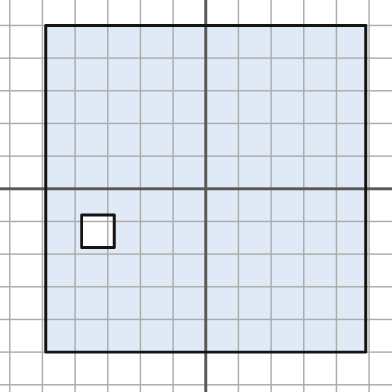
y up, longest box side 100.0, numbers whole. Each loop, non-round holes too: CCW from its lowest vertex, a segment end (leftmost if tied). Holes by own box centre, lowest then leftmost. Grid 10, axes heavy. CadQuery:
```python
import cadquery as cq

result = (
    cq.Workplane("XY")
    .moveTo(-49.0, -50.0)
    .lineTo(49.0, -50.0)
    .lineTo(49.0, 50.0)
    .lineTo(-49.0, 50.0)
    .close()
    .moveTo(-38.0, -18.0)
    .lineTo(-28.0, -18.0)
    .lineTo(-28.0, -8.0)
    .lineTo(-38.0, -8.0)
    .close()
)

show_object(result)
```